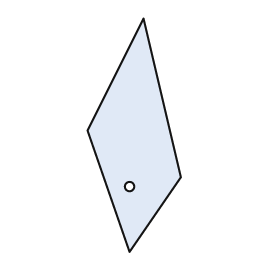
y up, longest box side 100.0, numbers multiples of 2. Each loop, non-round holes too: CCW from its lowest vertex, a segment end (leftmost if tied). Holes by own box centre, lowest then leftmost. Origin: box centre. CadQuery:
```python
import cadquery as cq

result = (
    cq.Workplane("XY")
    .moveTo(-2.0, -50.0)
    .lineTo(20.0, -18.0)
    .lineTo(4.0, 50.0)
    .lineTo(-20.0, 2.0)
    .close()
    .moveTo(-2.0, -22.0)
    .circle(2.0)
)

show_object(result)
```